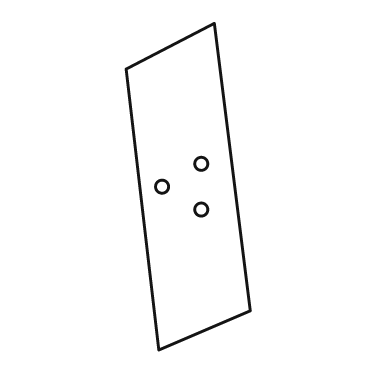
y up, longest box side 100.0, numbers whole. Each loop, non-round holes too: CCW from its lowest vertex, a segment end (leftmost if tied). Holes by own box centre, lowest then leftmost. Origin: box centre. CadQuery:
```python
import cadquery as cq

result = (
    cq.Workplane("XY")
    .moveTo(-9.0, -50.0)
    .lineTo(19.0, -38.0)
    .lineTo(8.0, 50.0)
    .lineTo(-19.0, 36.0)
    .close()
    .moveTo(4.0, -7.0)
    .circle(2.0)
    .moveTo(-8.0, 0.0)
    .circle(2.0)
    .moveTo(4.0, 7.0)
    .circle(2.0)
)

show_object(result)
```